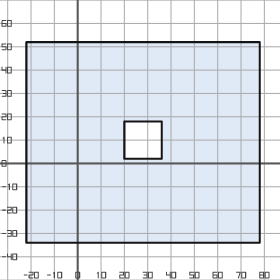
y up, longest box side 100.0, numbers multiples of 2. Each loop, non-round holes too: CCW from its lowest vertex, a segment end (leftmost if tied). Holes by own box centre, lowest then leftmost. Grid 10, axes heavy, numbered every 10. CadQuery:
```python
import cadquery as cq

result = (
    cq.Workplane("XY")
    .moveTo(-22.0, -34.0)
    .lineTo(78.0, -34.0)
    .lineTo(78.0, 52.0)
    .lineTo(-22.0, 52.0)
    .close()
    .moveTo(20.0, 2.0)
    .lineTo(36.0, 2.0)
    .lineTo(36.0, 18.0)
    .lineTo(20.0, 18.0)
    .close()
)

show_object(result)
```